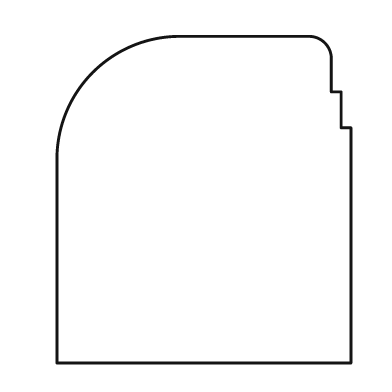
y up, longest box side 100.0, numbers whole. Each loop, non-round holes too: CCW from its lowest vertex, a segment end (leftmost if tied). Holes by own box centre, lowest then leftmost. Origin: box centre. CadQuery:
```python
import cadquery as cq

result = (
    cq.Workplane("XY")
    .moveTo(-45.0, -50.0)
    .lineTo(45.0, -50.0)
    .lineTo(45.0, 22.0)
    .lineTo(42.0, 22.0)
    .lineTo(42.0, 33.0)
    .lineTo(39.0, 33.0)
    .lineTo(39.0, 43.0)
    .threePointArc((37.0, 48.0), (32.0, 50.0))
    .lineTo(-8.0, 50.0)
    .threePointArc((-34.0, 39.0), (-45.0, 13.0))
    .close()
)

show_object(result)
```